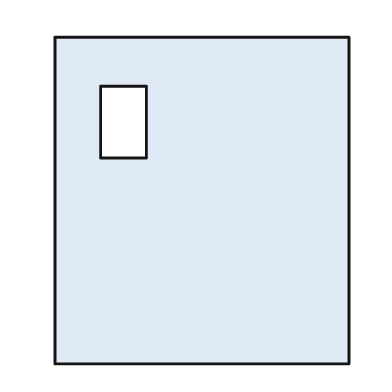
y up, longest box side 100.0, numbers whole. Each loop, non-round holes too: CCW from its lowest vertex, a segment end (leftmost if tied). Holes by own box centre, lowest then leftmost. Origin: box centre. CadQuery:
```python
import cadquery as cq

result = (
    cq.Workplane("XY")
    .moveTo(-45.0, -50.0)
    .lineTo(45.0, -50.0)
    .lineTo(45.0, 50.0)
    .lineTo(-45.0, 50.0)
    .close()
    .moveTo(-31.0, 13.0)
    .lineTo(-17.0, 13.0)
    .lineTo(-17.0, 35.0)
    .lineTo(-31.0, 35.0)
    .close()
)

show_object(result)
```